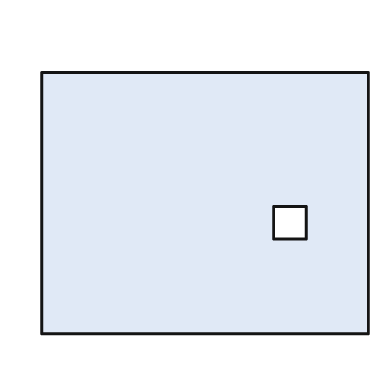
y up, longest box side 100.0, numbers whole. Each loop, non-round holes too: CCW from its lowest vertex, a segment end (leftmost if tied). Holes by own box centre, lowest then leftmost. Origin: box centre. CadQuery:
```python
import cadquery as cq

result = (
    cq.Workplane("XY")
    .moveTo(-50.0, -40.0)
    .lineTo(50.0, -40.0)
    .lineTo(50.0, 40.0)
    .lineTo(-50.0, 40.0)
    .close()
    .moveTo(21.0, -11.0)
    .lineTo(31.0, -11.0)
    .lineTo(31.0, -1.0)
    .lineTo(21.0, -1.0)
    .close()
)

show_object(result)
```